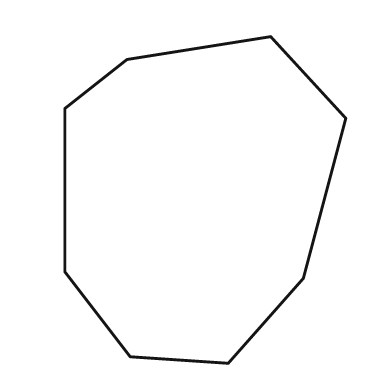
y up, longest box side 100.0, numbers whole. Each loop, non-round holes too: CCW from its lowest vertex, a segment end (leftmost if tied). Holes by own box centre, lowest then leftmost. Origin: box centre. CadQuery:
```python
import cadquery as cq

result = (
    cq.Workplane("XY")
    .moveTo(7.0, -50.0)
    .lineTo(30.0, -24.0)
    .lineTo(43.0, 25.0)
    .lineTo(20.0, 50.0)
    .lineTo(-24.0, 43.0)
    .lineTo(-43.0, 28.0)
    .lineTo(-43.0, -22.0)
    .lineTo(-23.0, -48.0)
    .close()
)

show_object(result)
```